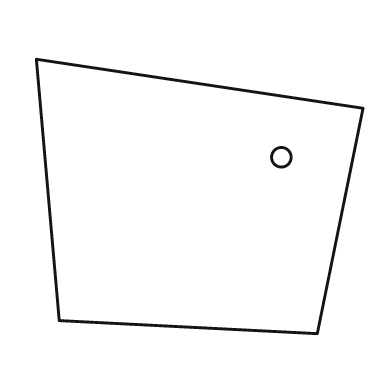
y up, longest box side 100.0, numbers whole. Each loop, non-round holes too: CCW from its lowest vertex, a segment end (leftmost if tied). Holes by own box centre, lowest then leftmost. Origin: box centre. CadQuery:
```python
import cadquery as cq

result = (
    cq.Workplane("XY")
    .moveTo(36.0, -42.0)
    .lineTo(50.0, 27.0)
    .lineTo(-50.0, 42.0)
    .lineTo(-43.0, -38.0)
    .close()
    .moveTo(25.0, 12.0)
    .circle(3.0)
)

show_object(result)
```